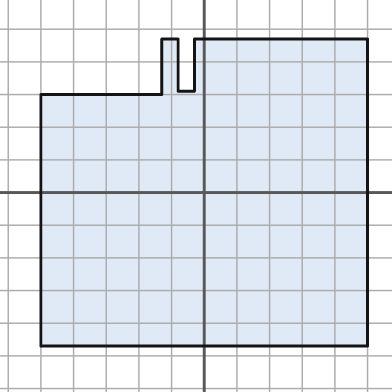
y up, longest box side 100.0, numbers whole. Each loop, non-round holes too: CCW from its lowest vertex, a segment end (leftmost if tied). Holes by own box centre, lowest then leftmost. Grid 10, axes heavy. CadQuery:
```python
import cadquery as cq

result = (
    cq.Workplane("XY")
    .moveTo(-50.0, -47.0)
    .lineTo(50.0, -47.0)
    .lineTo(50.0, 47.0)
    .lineTo(-3.0, 47.0)
    .lineTo(-3.0, 31.0)
    .lineTo(-8.0, 31.0)
    .lineTo(-8.0, 47.0)
    .lineTo(-13.0, 47.0)
    .lineTo(-13.0, 30.0)
    .lineTo(-50.0, 30.0)
    .close()
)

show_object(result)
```